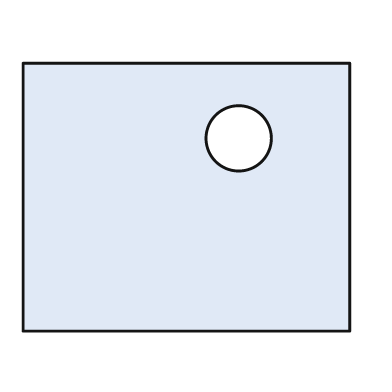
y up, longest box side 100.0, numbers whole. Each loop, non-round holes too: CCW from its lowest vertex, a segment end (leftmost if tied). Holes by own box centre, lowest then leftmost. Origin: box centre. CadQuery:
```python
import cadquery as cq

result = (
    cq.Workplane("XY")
    .moveTo(-50.0, -41.0)
    .lineTo(50.0, -41.0)
    .lineTo(50.0, 41.0)
    .lineTo(-50.0, 41.0)
    .close()
    .moveTo(16.0, 18.0)
    .circle(10.0)
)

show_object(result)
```